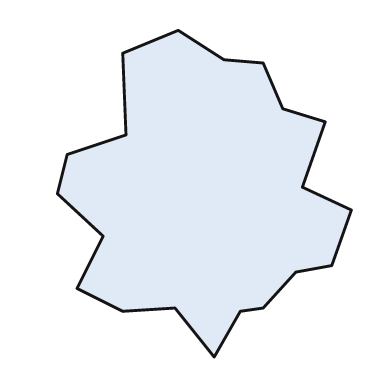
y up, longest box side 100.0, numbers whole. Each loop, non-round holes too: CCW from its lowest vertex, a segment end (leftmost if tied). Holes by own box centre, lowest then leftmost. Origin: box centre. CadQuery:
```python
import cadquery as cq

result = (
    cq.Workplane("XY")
    .moveTo(3.0, -50.0)
    .lineTo(11.0, -36.0)
    .lineTo(18.0, -35.0)
    .lineTo(28.0, -24.0)
    .lineTo(39.0, -22.0)
    .lineTo(45.0, -5.0)
    .lineTo(30.0, 2.0)
    .lineTo(37.0, 22.0)
    .lineTo(24.0, 26.0)
    .lineTo(18.0, 40.0)
    .lineTo(6.0, 41.0)
    .lineTo(-8.0, 50.0)
    .lineTo(-25.0, 43.0)
    .lineTo(-24.0, 18.0)
    .lineTo(-42.0, 12.0)
    .lineTo(-45.0, 0.0)
    .lineTo(-31.0, -13.0)
    .lineTo(-39.0, -29.0)
    .lineTo(-25.0, -36.0)
    .lineTo(-9.0, -35.0)
    .close()
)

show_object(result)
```